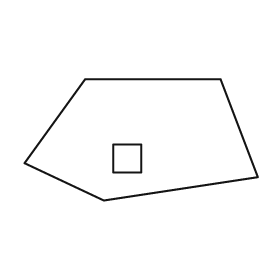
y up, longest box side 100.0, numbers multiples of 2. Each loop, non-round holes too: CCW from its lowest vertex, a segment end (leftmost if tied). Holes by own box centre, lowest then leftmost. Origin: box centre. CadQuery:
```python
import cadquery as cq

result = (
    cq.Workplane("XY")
    .moveTo(-16.0, -26.0)
    .lineTo(50.0, -16.0)
    .lineTo(34.0, 26.0)
    .lineTo(-24.0, 26.0)
    .lineTo(-50.0, -10.0)
    .close()
    .moveTo(-12.0, -14.0)
    .lineTo(0.0, -14.0)
    .lineTo(0.0, -2.0)
    .lineTo(-12.0, -2.0)
    .close()
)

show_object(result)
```